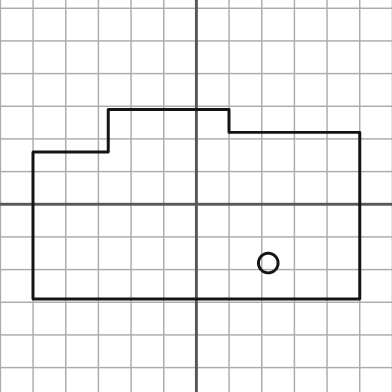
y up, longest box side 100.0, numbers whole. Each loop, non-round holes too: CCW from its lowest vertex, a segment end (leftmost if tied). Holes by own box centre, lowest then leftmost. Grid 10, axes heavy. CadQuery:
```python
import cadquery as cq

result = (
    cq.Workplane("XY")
    .moveTo(-50.0, -29.0)
    .lineTo(50.0, -29.0)
    .lineTo(50.0, 22.0)
    .lineTo(10.0, 22.0)
    .lineTo(10.0, 29.0)
    .lineTo(-27.0, 29.0)
    .lineTo(-27.0, 16.0)
    .lineTo(-50.0, 16.0)
    .close()
    .moveTo(22.0, -18.0)
    .circle(3.0)
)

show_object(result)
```